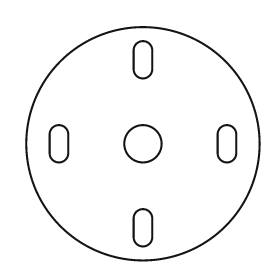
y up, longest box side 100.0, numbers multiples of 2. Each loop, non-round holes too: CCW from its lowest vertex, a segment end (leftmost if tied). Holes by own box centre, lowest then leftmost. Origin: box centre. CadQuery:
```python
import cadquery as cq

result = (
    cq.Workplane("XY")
    .moveTo(0.0, 0.0)
    .circle(50.0)
    .moveTo(-4.0, -40.0)
    .threePointArc((0.0, -44.0), (4.0, -40.0))
    .lineTo(4.0, -32.0)
    .threePointArc((0.0, -28.0), (-4.0, -32.0))
    .close()
    .moveTo(-40.0, -4.0)
    .threePointArc((-36.0, -8.0), (-32.0, -4.0))
    .lineTo(-32.0, 4.0)
    .threePointArc((-36.0, 8.0), (-40.0, 4.0))
    .close()
    .moveTo(0.0, 0.0)
    .circle(8.0)
    .moveTo(32.0, -4.0)
    .threePointArc((36.0, -8.0), (40.0, -4.0))
    .lineTo(40.0, 4.0)
    .threePointArc((36.0, 8.0), (32.0, 4.0))
    .close()
    .moveTo(-4.0, 32.0)
    .threePointArc((0.0, 28.0), (4.0, 32.0))
    .lineTo(4.0, 40.0)
    .threePointArc((0.0, 44.0), (-4.0, 40.0))
    .close()
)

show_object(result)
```